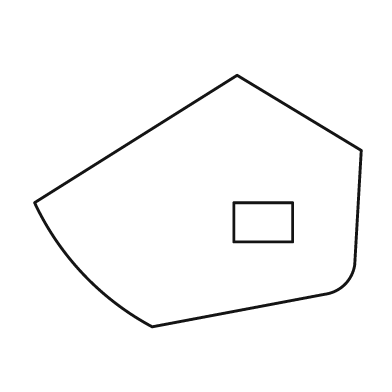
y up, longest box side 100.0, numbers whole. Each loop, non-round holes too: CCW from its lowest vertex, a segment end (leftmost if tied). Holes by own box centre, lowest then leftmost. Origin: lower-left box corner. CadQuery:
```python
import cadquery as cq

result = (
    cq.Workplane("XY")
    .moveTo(36.0, 0.0)
    .lineTo(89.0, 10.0)
    .threePointArc((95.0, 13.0), (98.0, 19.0))
    .lineTo(100.0, 54.0)
    .lineTo(62.0, 77.0)
    .lineTo(0.0, 38.0)
    .threePointArc((15.0, 16.0), (36.0, 0.0))
    .close()
    .moveTo(61.0, 26.0)
    .lineTo(79.0, 26.0)
    .lineTo(79.0, 38.0)
    .lineTo(61.0, 38.0)
    .close()
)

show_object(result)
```